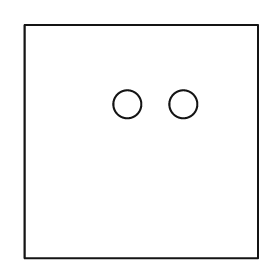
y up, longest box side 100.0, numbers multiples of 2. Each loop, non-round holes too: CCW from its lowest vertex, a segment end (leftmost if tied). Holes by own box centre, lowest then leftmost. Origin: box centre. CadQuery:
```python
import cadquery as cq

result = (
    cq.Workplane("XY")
    .moveTo(-50.0, -50.0)
    .lineTo(50.0, -50.0)
    .lineTo(50.0, 50.0)
    .lineTo(-50.0, 50.0)
    .close()
    .moveTo(-6.0, 16.0)
    .circle(6.0)
    .moveTo(18.0, 16.0)
    .circle(6.0)
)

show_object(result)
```